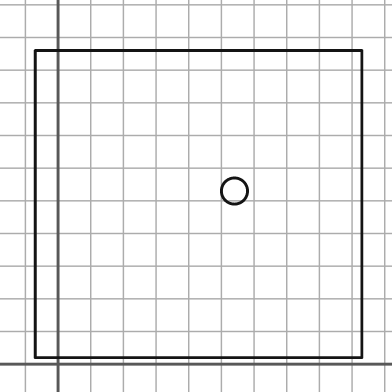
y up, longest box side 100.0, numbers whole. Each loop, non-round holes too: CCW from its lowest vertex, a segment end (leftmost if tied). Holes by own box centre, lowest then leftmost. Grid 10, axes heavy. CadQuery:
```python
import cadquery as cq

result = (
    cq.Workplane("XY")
    .moveTo(-7.0, 2.0)
    .lineTo(93.0, 2.0)
    .lineTo(93.0, 96.0)
    .lineTo(-7.0, 96.0)
    .close()
    .moveTo(54.0, 53.0)
    .circle(4.0)
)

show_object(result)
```